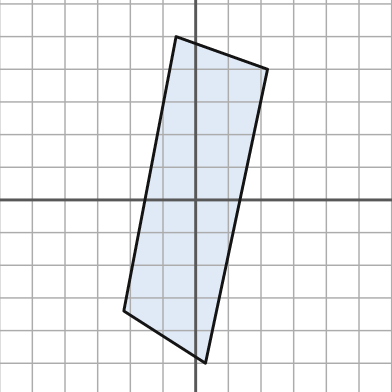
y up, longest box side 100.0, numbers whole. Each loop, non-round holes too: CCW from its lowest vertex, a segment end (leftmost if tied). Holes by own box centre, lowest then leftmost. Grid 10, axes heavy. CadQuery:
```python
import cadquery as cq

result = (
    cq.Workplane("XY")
    .moveTo(3.0, -50.0)
    .lineTo(22.0, 40.0)
    .lineTo(-6.0, 50.0)
    .lineTo(-22.0, -34.0)
    .close()
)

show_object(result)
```